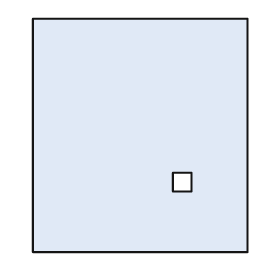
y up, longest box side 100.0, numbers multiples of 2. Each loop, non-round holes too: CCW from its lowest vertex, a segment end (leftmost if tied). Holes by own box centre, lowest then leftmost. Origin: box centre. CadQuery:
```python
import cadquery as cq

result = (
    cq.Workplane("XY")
    .moveTo(-46.0, -50.0)
    .lineTo(46.0, -50.0)
    .lineTo(46.0, 50.0)
    .lineTo(-46.0, 50.0)
    .close()
    .moveTo(14.0, -24.0)
    .lineTo(22.0, -24.0)
    .lineTo(22.0, -16.0)
    .lineTo(14.0, -16.0)
    .close()
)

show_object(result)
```